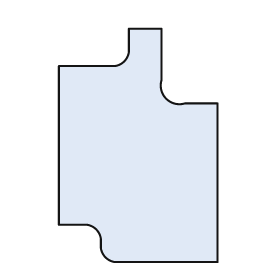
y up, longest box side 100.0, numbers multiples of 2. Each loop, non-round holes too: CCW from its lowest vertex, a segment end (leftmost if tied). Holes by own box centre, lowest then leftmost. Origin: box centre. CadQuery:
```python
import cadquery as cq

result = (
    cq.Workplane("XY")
    .moveTo(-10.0, -50.0)
    .lineTo(34.0, -50.0)
    .lineTo(34.0, 18.0)
    .lineTo(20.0, 18.0)
    .threePointArc((12.0, 20.0), (10.0, 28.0))
    .lineTo(10.0, 50.0)
    .lineTo(-4.0, 50.0)
    .lineTo(-4.0, 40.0)
    .threePointArc((-6.0, 36.0), (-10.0, 34.0))
    .lineTo(-34.0, 34.0)
    .lineTo(-34.0, -34.0)
    .lineTo(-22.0, -34.0)
    .threePointArc((-18.0, -36.0), (-16.0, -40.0))
    .lineTo(-16.0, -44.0)
    .threePointArc((-14.0, -48.0), (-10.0, -50.0))
    .close()
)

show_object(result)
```